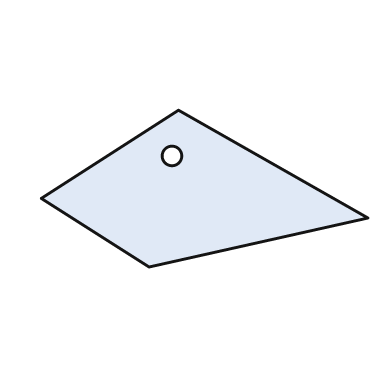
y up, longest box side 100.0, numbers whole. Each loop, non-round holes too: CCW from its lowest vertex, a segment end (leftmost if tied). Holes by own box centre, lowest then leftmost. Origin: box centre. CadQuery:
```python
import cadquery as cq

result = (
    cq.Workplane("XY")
    .moveTo(-17.0, -24.0)
    .lineTo(50.0, -9.0)
    .lineTo(-8.0, 24.0)
    .lineTo(-50.0, -3.0)
    .close()
    .moveTo(-10.0, 10.0)
    .circle(3.0)
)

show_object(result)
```